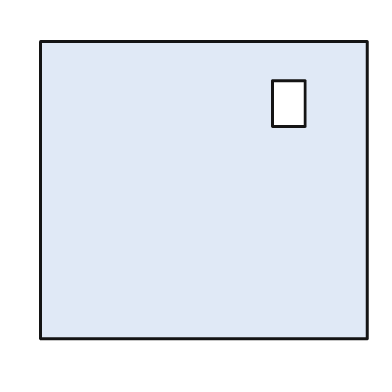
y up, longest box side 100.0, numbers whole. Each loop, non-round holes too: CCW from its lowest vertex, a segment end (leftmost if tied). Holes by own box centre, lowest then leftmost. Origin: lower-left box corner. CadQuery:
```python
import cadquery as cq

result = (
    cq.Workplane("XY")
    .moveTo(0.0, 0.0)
    .lineTo(100.0, 0.0)
    .lineTo(100.0, 91.0)
    .lineTo(0.0, 91.0)
    .close()
    .moveTo(71.0, 65.0)
    .lineTo(81.0, 65.0)
    .lineTo(81.0, 79.0)
    .lineTo(71.0, 79.0)
    .close()
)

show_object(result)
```